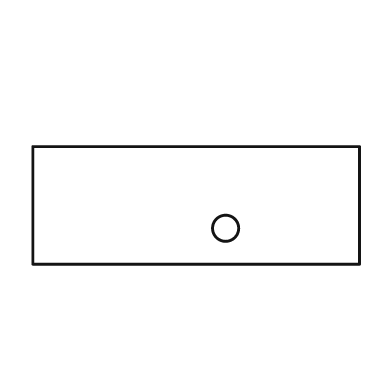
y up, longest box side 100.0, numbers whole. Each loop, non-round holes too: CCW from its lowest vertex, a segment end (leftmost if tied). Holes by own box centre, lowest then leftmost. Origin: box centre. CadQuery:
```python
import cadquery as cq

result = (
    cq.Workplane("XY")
    .moveTo(-50.0, -18.0)
    .lineTo(50.0, -18.0)
    .lineTo(50.0, 18.0)
    .lineTo(-50.0, 18.0)
    .close()
    .moveTo(9.0, -7.0)
    .circle(4.0)
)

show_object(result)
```